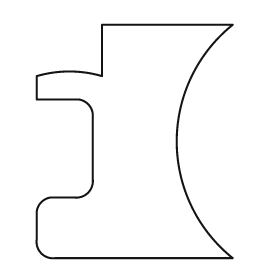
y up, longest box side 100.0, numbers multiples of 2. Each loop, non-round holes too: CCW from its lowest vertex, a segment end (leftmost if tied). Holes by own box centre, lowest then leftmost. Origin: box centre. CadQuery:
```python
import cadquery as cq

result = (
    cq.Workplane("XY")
    .moveTo(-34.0, -50.0)
    .lineTo(42.0, -50.0)
    .threePointArc((18.0, 0.0), (42.0, 50.0))
    .lineTo(-14.0, 50.0)
    .lineTo(-14.0, 28.0)
    .threePointArc((-28.0, 30.0), (-42.0, 28.0))
    .lineTo(-42.0, 18.0)
    .lineTo(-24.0, 18.0)
    .threePointArc((-20.0, 16.0), (-18.0, 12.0))
    .lineTo(-18.0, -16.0)
    .threePointArc((-20.0, -22.0), (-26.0, -24.0))
    .lineTo(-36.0, -24.0)
    .threePointArc((-40.0, -26.0), (-42.0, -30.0))
    .lineTo(-42.0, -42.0)
    .threePointArc((-40.0, -48.0), (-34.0, -50.0))
    .close()
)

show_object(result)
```